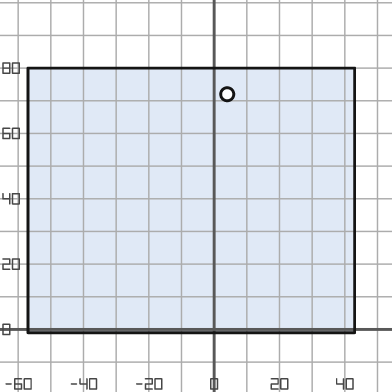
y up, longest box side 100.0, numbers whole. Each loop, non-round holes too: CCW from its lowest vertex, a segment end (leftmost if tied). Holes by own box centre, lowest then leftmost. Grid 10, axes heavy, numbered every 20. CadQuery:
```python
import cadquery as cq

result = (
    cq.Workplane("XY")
    .moveTo(-57.0, -1.0)
    .lineTo(43.0, -1.0)
    .lineTo(43.0, 80.0)
    .lineTo(-57.0, 80.0)
    .close()
    .moveTo(4.0, 72.0)
    .circle(2.0)
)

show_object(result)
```